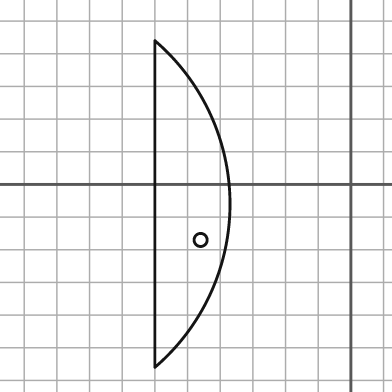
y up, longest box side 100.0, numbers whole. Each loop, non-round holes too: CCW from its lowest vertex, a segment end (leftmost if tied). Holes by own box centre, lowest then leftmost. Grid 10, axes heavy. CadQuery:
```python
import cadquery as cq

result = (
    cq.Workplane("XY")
    .moveTo(-60.0, -56.0)
    .threePointArc((-37.0, -6.0), (-60.0, 44.0))
    .close()
    .moveTo(-46.0, -17.0)
    .circle(2.0)
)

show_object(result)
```